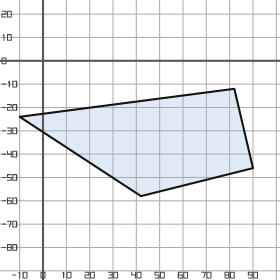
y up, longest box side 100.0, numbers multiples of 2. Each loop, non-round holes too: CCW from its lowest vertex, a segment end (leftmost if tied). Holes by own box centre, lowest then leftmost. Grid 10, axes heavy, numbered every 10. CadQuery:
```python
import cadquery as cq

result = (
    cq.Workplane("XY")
    .moveTo(42.0, -58.0)
    .lineTo(90.0, -46.0)
    .lineTo(82.0, -12.0)
    .lineTo(-10.0, -24.0)
    .close()
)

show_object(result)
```